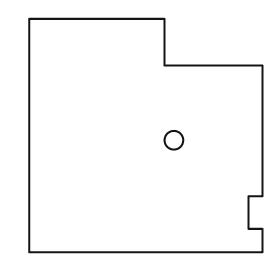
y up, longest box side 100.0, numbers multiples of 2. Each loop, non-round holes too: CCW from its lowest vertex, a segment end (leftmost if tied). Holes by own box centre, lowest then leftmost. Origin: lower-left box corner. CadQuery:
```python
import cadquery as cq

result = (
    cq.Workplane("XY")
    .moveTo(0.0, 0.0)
    .lineTo(100.0, 0.0)
    .lineTo(100.0, 10.0)
    .lineTo(94.0, 10.0)
    .lineTo(94.0, 24.0)
    .lineTo(100.0, 24.0)
    .lineTo(100.0, 80.0)
    .lineTo(58.0, 80.0)
    .lineTo(58.0, 100.0)
    .lineTo(0.0, 100.0)
    .close()
    .moveTo(62.0, 48.0)
    .circle(4.0)
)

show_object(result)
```